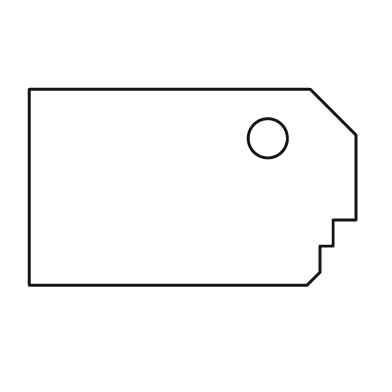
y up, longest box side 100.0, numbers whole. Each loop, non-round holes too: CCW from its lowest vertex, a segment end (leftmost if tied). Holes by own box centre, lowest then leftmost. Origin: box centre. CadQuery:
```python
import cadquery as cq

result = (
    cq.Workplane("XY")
    .moveTo(-50.0, -30.0)
    .lineTo(35.0, -30.0)
    .lineTo(39.0, -26.0)
    .lineTo(39.0, -18.0)
    .lineTo(43.0, -18.0)
    .lineTo(43.0, -10.0)
    .lineTo(50.0, -10.0)
    .lineTo(50.0, 16.0)
    .lineTo(36.0, 30.0)
    .lineTo(-50.0, 30.0)
    .close()
    .moveTo(23.0, 15.0)
    .circle(6.0)
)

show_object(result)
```